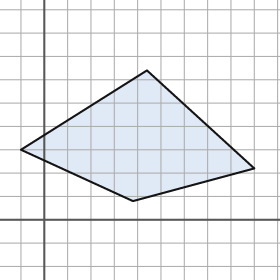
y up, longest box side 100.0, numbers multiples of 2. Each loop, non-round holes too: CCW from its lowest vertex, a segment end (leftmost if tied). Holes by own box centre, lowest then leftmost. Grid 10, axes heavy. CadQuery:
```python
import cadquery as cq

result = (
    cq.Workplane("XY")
    .moveTo(38.0, 8.0)
    .lineTo(90.0, 22.0)
    .lineTo(44.0, 64.0)
    .lineTo(-10.0, 30.0)
    .close()
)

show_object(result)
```